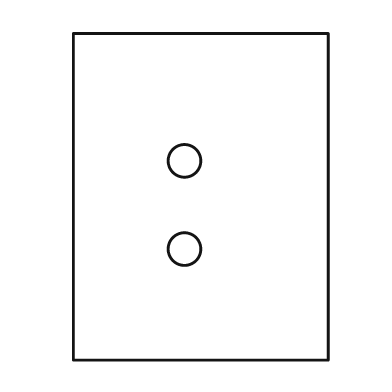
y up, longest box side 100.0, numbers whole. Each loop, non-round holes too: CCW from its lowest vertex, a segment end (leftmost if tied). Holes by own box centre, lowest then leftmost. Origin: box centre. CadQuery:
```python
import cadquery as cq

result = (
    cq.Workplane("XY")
    .moveTo(-39.0, -50.0)
    .lineTo(39.0, -50.0)
    .lineTo(39.0, 50.0)
    .lineTo(-39.0, 50.0)
    .close()
    .moveTo(-5.0, -16.0)
    .circle(5.0)
    .moveTo(-5.0, 11.0)
    .circle(5.0)
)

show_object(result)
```